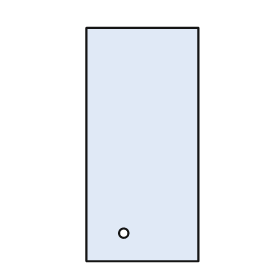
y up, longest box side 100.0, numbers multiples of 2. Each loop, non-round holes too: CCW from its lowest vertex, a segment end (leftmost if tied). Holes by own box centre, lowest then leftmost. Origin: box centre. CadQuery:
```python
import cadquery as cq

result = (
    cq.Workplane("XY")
    .moveTo(-24.0, -50.0)
    .lineTo(24.0, -50.0)
    .lineTo(24.0, 50.0)
    .lineTo(-24.0, 50.0)
    .close()
    .moveTo(-8.0, -38.0)
    .circle(2.0)
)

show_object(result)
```